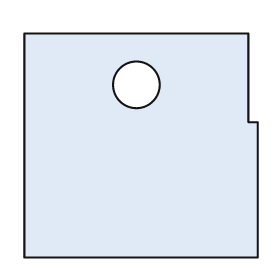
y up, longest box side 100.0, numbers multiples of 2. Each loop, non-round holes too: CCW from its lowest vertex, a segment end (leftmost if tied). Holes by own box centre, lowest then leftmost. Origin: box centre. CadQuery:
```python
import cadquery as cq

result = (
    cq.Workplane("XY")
    .moveTo(-50.0, -48.0)
    .lineTo(50.0, -48.0)
    .lineTo(50.0, 10.0)
    .lineTo(46.0, 10.0)
    .lineTo(46.0, 48.0)
    .lineTo(-50.0, 48.0)
    .close()
    .moveTo(-2.0, 26.0)
    .circle(10.0)
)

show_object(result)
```